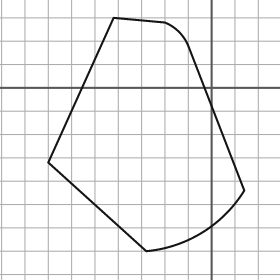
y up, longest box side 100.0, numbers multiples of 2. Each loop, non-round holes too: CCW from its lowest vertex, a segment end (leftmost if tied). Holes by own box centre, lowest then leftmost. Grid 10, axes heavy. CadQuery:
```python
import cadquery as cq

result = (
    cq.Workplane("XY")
    .moveTo(-28.0, -70.0)
    .threePointArc((-4.0, -62.0), (14.0, -44.0))
    .lineTo(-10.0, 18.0)
    .threePointArc((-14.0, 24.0), (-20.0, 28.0))
    .lineTo(-42.0, 30.0)
    .lineTo(-70.0, -32.0)
    .close()
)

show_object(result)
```